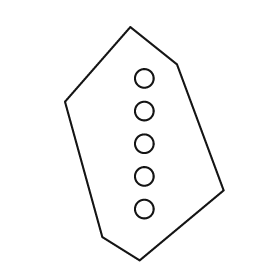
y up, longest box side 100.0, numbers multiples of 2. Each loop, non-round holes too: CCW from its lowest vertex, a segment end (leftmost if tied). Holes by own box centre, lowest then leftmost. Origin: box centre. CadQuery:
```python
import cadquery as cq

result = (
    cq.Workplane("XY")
    .moveTo(-2.0, -50.0)
    .lineTo(34.0, -20.0)
    .lineTo(14.0, 34.0)
    .lineTo(-6.0, 50.0)
    .lineTo(-34.0, 18.0)
    .lineTo(-18.0, -40.0)
    .close()
    .moveTo(0.0, -28.0)
    .circle(4.0)
    .moveTo(0.0, -14.0)
    .circle(4.0)
    .moveTo(0.0, 0.0)
    .circle(4.0)
    .moveTo(0.0, 14.0)
    .circle(4.0)
    .moveTo(0.0, 28.0)
    .circle(4.0)
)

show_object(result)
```